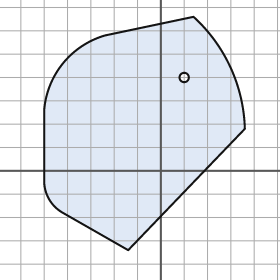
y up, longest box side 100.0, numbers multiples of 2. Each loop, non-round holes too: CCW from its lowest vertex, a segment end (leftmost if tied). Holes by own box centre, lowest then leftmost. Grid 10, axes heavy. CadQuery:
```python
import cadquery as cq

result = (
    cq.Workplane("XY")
    .moveTo(-14.0, -34.0)
    .lineTo(36.0, 18.0)
    .threePointArc((30.0, 44.0), (14.0, 66.0))
    .lineTo(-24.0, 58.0)
    .threePointArc((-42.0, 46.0), (-50.0, 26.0))
    .lineTo(-50.0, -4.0)
    .threePointArc((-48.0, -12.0), (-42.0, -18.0))
    .close()
    .moveTo(10.0, 40.0)
    .circle(2.0)
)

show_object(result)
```